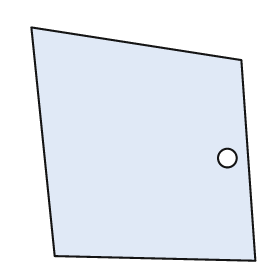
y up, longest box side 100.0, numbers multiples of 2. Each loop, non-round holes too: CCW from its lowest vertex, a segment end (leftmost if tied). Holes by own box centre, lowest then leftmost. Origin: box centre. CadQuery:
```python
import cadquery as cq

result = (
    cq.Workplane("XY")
    .moveTo(48.0, -50.0)
    .lineTo(42.0, 36.0)
    .lineTo(-48.0, 50.0)
    .lineTo(-38.0, -48.0)
    .close()
    .moveTo(36.0, -6.0)
    .circle(4.0)
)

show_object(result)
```